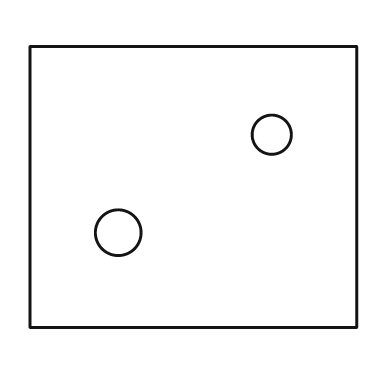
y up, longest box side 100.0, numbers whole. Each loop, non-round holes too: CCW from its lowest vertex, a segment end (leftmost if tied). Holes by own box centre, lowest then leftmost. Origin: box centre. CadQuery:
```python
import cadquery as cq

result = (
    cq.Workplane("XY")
    .moveTo(-50.0, -43.0)
    .lineTo(50.0, -43.0)
    .lineTo(50.0, 43.0)
    .lineTo(-50.0, 43.0)
    .close()
    .moveTo(-23.0, -14.0)
    .circle(7.0)
    .moveTo(24.0, 16.0)
    .circle(6.0)
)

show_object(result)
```